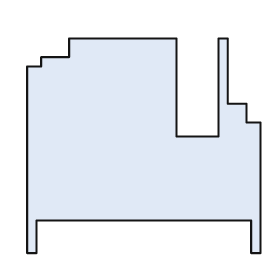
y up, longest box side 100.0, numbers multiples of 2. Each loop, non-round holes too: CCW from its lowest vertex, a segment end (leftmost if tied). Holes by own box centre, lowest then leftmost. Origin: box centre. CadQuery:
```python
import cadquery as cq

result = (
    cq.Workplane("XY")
    .moveTo(-50.0, -46.0)
    .lineTo(-46.0, -46.0)
    .lineTo(-46.0, -32.0)
    .lineTo(46.0, -32.0)
    .lineTo(46.0, -46.0)
    .lineTo(50.0, -46.0)
    .lineTo(50.0, 10.0)
    .lineTo(44.0, 10.0)
    .lineTo(44.0, 18.0)
    .lineTo(36.0, 18.0)
    .lineTo(36.0, 46.0)
    .lineTo(32.0, 46.0)
    .lineTo(32.0, 4.0)
    .lineTo(14.0, 4.0)
    .lineTo(14.0, 46.0)
    .lineTo(-32.0, 46.0)
    .lineTo(-32.0, 38.0)
    .lineTo(-44.0, 38.0)
    .lineTo(-44.0, 34.0)
    .lineTo(-50.0, 34.0)
    .close()
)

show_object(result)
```